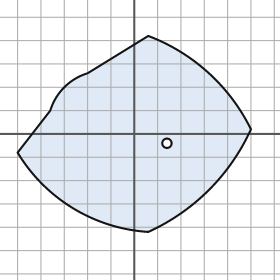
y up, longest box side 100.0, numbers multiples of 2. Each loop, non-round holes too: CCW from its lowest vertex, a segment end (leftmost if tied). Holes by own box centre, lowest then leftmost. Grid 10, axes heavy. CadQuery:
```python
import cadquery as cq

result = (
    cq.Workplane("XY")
    .moveTo(6.0, -42.0)
    .threePointArc((32.0, -24.0), (50.0, 2.0))
    .threePointArc((32.0, 26.0), (6.0, 42.0))
    .lineTo(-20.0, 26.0)
    .threePointArc((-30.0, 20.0), (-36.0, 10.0))
    .lineTo(-50.0, -8.0)
    .threePointArc((-26.0, -32.0), (6.0, -42.0))
    .close()
    .moveTo(14.0, -4.0)
    .circle(2.0)
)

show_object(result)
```